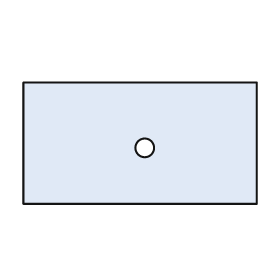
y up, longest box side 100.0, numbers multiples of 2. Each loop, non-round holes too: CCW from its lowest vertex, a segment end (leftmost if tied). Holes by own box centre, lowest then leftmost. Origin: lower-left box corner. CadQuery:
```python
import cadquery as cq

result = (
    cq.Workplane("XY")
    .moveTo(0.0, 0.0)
    .lineTo(100.0, 0.0)
    .lineTo(100.0, 52.0)
    .lineTo(0.0, 52.0)
    .close()
    .moveTo(52.0, 24.0)
    .circle(4.0)
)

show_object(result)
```